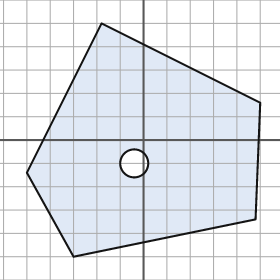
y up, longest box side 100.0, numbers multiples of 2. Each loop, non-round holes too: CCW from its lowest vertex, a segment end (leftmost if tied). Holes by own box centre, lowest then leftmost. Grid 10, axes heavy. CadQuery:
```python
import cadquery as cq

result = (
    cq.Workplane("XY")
    .moveTo(-30.0, -50.0)
    .lineTo(48.0, -34.0)
    .lineTo(50.0, 16.0)
    .lineTo(-18.0, 50.0)
    .lineTo(-50.0, -14.0)
    .close()
    .moveTo(-4.0, -10.0)
    .circle(6.0)
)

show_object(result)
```